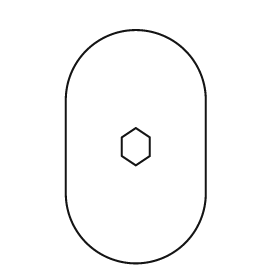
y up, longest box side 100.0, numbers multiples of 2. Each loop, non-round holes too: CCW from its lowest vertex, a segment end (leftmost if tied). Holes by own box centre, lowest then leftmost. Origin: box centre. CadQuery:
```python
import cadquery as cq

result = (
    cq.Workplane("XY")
    .moveTo(-30.0, -20.0)
    .threePointArc((0.0, -50.0), (30.0, -20.0))
    .lineTo(30.0, 20.0)
    .threePointArc((0.0, 50.0), (-30.0, 20.0))
    .close()
    .moveTo(0.0, -8.0)
    .lineTo(6.0, -4.0)
    .lineTo(6.0, 4.0)
    .lineTo(0.0, 8.0)
    .lineTo(-6.0, 4.0)
    .lineTo(-6.0, -4.0)
    .close()
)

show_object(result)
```